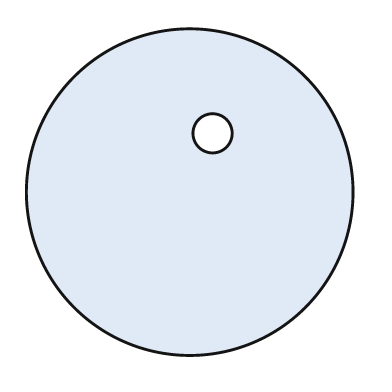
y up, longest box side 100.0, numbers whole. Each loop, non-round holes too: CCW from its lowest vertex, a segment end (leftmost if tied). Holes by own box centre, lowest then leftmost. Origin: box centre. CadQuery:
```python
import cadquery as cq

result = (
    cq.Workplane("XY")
    .moveTo(0.0, 0.0)
    .circle(50.0)
    .moveTo(7.0, 18.0)
    .circle(6.0)
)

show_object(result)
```